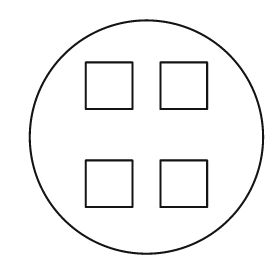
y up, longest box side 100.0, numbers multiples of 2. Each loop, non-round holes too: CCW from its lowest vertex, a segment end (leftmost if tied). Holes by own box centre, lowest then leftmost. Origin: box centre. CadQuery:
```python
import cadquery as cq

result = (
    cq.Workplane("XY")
    .moveTo(0.0, 0.0)
    .circle(50.0)
    .moveTo(-26.0, -30.0)
    .lineTo(-6.0, -30.0)
    .lineTo(-6.0, -10.0)
    .lineTo(-26.0, -10.0)
    .close()
    .moveTo(6.0, -30.0)
    .lineTo(26.0, -30.0)
    .lineTo(26.0, -10.0)
    .lineTo(6.0, -10.0)
    .close()
    .moveTo(-26.0, 12.0)
    .lineTo(-6.0, 12.0)
    .lineTo(-6.0, 32.0)
    .lineTo(-26.0, 32.0)
    .close()
    .moveTo(6.0, 12.0)
    .lineTo(26.0, 12.0)
    .lineTo(26.0, 32.0)
    .lineTo(6.0, 32.0)
    .close()
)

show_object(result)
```